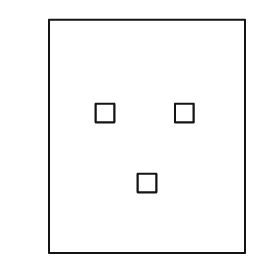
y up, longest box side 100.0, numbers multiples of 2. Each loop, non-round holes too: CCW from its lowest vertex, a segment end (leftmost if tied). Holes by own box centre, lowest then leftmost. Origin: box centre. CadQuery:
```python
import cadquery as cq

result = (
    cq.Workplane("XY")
    .moveTo(-42.0, -50.0)
    .lineTo(42.0, -50.0)
    .lineTo(42.0, 50.0)
    .lineTo(-42.0, 50.0)
    .close()
    .moveTo(-4.0, -24.0)
    .lineTo(4.0, -24.0)
    .lineTo(4.0, -16.0)
    .lineTo(-4.0, -16.0)
    .close()
    .moveTo(-22.0, 6.0)
    .lineTo(-14.0, 6.0)
    .lineTo(-14.0, 14.0)
    .lineTo(-22.0, 14.0)
    .close()
    .moveTo(12.0, 6.0)
    .lineTo(20.0, 6.0)
    .lineTo(20.0, 14.0)
    .lineTo(12.0, 14.0)
    .close()
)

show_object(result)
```